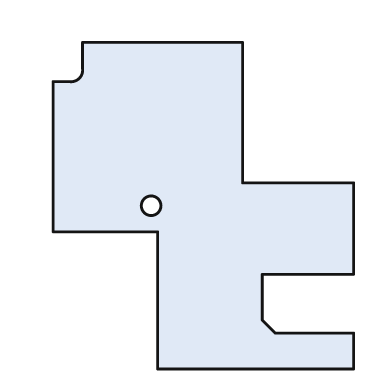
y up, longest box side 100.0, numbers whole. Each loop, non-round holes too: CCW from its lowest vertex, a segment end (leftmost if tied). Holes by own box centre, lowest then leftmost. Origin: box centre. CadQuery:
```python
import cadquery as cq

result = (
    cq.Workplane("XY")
    .moveTo(-14.0, -50.0)
    .lineTo(46.0, -50.0)
    .lineTo(46.0, -39.0)
    .lineTo(22.0, -39.0)
    .lineTo(18.0, -35.0)
    .lineTo(18.0, -21.0)
    .lineTo(46.0, -21.0)
    .lineTo(46.0, 7.0)
    .lineTo(12.0, 7.0)
    .lineTo(12.0, 50.0)
    .lineTo(-37.0, 50.0)
    .lineTo(-37.0, 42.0)
    .threePointArc((-38.0, 39.0), (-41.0, 38.0))
    .lineTo(-46.0, 38.0)
    .lineTo(-46.0, -8.0)
    .lineTo(-14.0, -8.0)
    .close()
    .moveTo(-16.0, 0.0)
    .circle(3.0)
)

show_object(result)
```